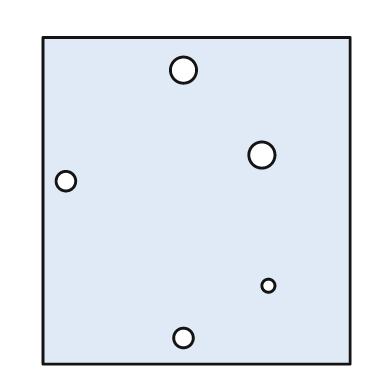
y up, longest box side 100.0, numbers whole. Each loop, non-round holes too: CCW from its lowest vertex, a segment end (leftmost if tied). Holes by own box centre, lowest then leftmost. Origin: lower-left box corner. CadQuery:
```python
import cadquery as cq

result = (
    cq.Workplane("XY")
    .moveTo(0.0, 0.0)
    .lineTo(94.0, 0.0)
    .lineTo(94.0, 100.0)
    .lineTo(0.0, 100.0)
    .close()
    .moveTo(43.0, 8.0)
    .circle(3.0)
    .moveTo(69.0, 24.0)
    .circle(2.0)
    .moveTo(7.0, 56.0)
    .circle(3.0)
    .moveTo(67.0, 64.0)
    .circle(4.0)
    .moveTo(43.0, 90.0)
    .circle(4.0)
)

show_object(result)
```